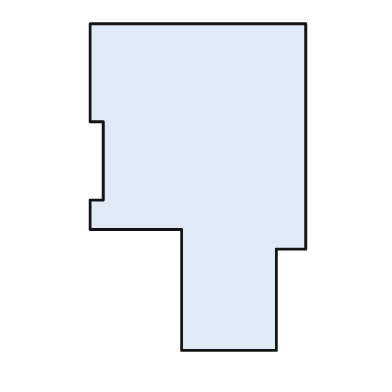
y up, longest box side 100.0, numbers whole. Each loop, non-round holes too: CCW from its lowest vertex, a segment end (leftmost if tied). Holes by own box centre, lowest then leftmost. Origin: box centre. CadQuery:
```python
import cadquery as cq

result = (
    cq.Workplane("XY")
    .moveTo(-5.0, -50.0)
    .lineTo(24.0, -50.0)
    .lineTo(24.0, -19.0)
    .lineTo(33.0, -19.0)
    .lineTo(33.0, 50.0)
    .lineTo(-33.0, 50.0)
    .lineTo(-33.0, 20.0)
    .lineTo(-29.0, 20.0)
    .lineTo(-29.0, -4.0)
    .lineTo(-33.0, -4.0)
    .lineTo(-33.0, -13.0)
    .lineTo(-5.0, -13.0)
    .close()
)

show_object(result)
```